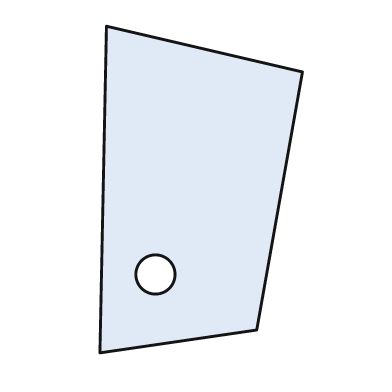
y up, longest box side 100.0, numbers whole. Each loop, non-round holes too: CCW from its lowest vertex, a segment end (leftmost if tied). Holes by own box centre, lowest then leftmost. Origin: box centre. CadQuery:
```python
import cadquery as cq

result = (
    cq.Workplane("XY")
    .moveTo(-31.0, -50.0)
    .lineTo(17.0, -43.0)
    .lineTo(31.0, 36.0)
    .lineTo(-29.0, 50.0)
    .close()
    .moveTo(-14.0, -26.0)
    .circle(6.0)
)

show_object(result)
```